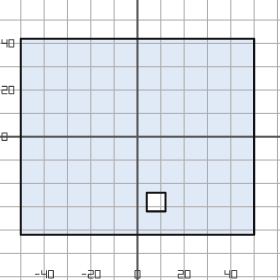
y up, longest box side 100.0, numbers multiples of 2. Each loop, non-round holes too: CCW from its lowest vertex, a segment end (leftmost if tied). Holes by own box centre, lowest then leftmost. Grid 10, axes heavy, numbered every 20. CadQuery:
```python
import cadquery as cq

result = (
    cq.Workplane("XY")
    .moveTo(-50.0, -42.0)
    .lineTo(50.0, -42.0)
    .lineTo(50.0, 42.0)
    .lineTo(-50.0, 42.0)
    .close()
    .moveTo(4.0, -32.0)
    .lineTo(12.0, -32.0)
    .lineTo(12.0, -24.0)
    .lineTo(4.0, -24.0)
    .close()
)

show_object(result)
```